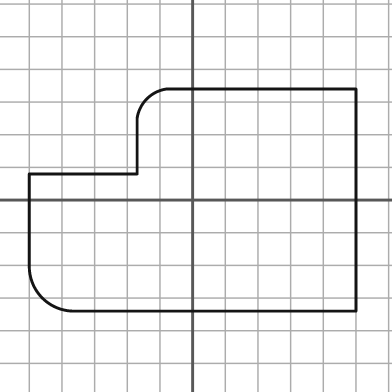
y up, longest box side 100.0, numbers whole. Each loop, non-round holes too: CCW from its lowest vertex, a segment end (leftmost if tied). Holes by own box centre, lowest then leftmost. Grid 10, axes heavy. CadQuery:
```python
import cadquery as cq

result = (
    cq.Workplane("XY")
    .moveTo(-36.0, -34.0)
    .lineTo(50.0, -34.0)
    .lineTo(50.0, 34.0)
    .lineTo(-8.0, 34.0)
    .threePointArc((-14.0, 31.0), (-17.0, 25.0))
    .lineTo(-17.0, 8.0)
    .lineTo(-50.0, 8.0)
    .lineTo(-50.0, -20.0)
    .threePointArc((-46.0, -30.0), (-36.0, -34.0))
    .close()
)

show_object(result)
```